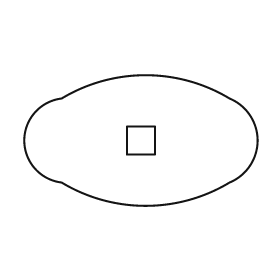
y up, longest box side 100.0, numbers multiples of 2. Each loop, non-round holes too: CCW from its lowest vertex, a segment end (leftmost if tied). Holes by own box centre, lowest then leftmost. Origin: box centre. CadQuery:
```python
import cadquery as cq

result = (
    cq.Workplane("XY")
    .moveTo(-34.0, -18.0)
    .threePointArc((2.0, -28.0), (38.0, -18.0))
    .threePointArc((50.0, 0.0), (38.0, 18.0))
    .threePointArc((2.0, 28.0), (-34.0, 18.0))
    .threePointArc((-50.0, 0.0), (-34.0, -18.0))
    .close()
    .moveTo(-6.0, -6.0)
    .lineTo(6.0, -6.0)
    .lineTo(6.0, 6.0)
    .lineTo(-6.0, 6.0)
    .close()
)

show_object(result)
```